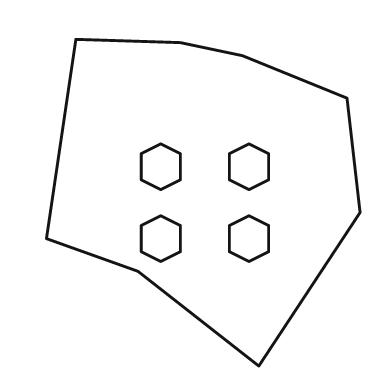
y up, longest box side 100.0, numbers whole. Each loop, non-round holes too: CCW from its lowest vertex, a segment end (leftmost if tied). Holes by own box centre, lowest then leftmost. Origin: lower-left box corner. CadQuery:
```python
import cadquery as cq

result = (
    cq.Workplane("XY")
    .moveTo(65.0, 0.0)
    .lineTo(96.0, 47.0)
    .lineTo(92.0, 82.0)
    .lineTo(60.0, 95.0)
    .lineTo(41.0, 99.0)
    .lineTo(9.0, 100.0)
    .lineTo(0.0, 39.0)
    .lineTo(28.0, 29.0)
    .close()
    .moveTo(35.0, 32.0)
    .lineTo(41.0, 35.0)
    .lineTo(41.0, 43.0)
    .lineTo(35.0, 46.0)
    .lineTo(29.0, 43.0)
    .lineTo(29.0, 35.0)
    .close()
    .moveTo(62.0, 32.0)
    .lineTo(68.0, 35.0)
    .lineTo(68.0, 43.0)
    .lineTo(62.0, 46.0)
    .lineTo(56.0, 43.0)
    .lineTo(56.0, 35.0)
    .close()
    .moveTo(35.0, 54.0)
    .lineTo(41.0, 57.0)
    .lineTo(41.0, 65.0)
    .lineTo(35.0, 68.0)
    .lineTo(29.0, 65.0)
    .lineTo(29.0, 57.0)
    .close()
    .moveTo(62.0, 54.0)
    .lineTo(68.0, 57.0)
    .lineTo(68.0, 65.0)
    .lineTo(62.0, 68.0)
    .lineTo(56.0, 65.0)
    .lineTo(56.0, 57.0)
    .close()
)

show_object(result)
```